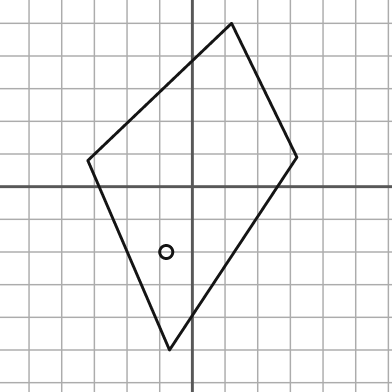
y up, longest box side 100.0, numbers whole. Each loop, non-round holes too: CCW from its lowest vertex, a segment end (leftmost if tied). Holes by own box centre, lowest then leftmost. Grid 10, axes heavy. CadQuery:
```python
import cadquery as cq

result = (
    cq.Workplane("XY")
    .moveTo(-7.0, -50.0)
    .lineTo(32.0, 9.0)
    .lineTo(12.0, 50.0)
    .lineTo(-32.0, 8.0)
    .close()
    .moveTo(-8.0, -20.0)
    .circle(2.0)
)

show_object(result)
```